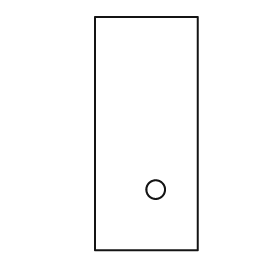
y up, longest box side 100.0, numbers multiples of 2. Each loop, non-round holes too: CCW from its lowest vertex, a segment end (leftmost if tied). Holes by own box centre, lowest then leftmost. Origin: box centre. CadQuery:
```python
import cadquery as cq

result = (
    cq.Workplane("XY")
    .moveTo(-22.0, -50.0)
    .lineTo(22.0, -50.0)
    .lineTo(22.0, 50.0)
    .lineTo(-22.0, 50.0)
    .close()
    .moveTo(4.0, -24.0)
    .circle(4.0)
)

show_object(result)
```